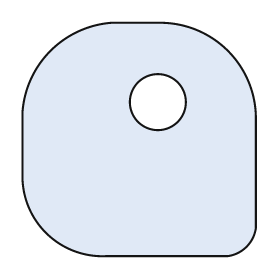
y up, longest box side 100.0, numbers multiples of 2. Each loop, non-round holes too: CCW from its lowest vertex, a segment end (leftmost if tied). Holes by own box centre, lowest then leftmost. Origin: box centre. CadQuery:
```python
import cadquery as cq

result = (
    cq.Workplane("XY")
    .moveTo(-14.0, -50.0)
    .lineTo(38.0, -50.0)
    .threePointArc((46.0, -46.0), (50.0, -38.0))
    .lineTo(50.0, 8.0)
    .threePointArc((38.0, 38.0), (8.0, 50.0))
    .lineTo(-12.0, 50.0)
    .threePointArc((-38.0, 38.0), (-50.0, 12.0))
    .lineTo(-50.0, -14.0)
    .threePointArc((-40.0, -40.0), (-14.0, -50.0))
    .close()
    .moveTo(8.0, 16.0)
    .circle(12.0)
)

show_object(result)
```